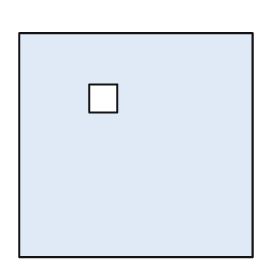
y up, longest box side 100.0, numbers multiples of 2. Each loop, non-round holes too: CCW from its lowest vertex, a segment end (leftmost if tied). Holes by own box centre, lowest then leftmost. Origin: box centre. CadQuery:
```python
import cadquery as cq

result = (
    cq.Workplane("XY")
    .moveTo(-50.0, -48.0)
    .lineTo(50.0, -48.0)
    .lineTo(50.0, 48.0)
    .lineTo(-50.0, 48.0)
    .close()
    .moveTo(-20.0, 14.0)
    .lineTo(-8.0, 14.0)
    .lineTo(-8.0, 26.0)
    .lineTo(-20.0, 26.0)
    .close()
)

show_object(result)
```